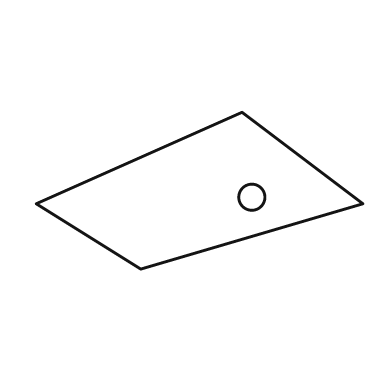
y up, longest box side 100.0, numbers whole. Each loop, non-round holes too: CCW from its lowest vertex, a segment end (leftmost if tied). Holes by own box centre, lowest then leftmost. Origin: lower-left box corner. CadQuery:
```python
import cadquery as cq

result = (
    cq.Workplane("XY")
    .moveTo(32.0, 0.0)
    .lineTo(100.0, 20.0)
    .lineTo(63.0, 48.0)
    .lineTo(0.0, 20.0)
    .close()
    .moveTo(66.0, 22.0)
    .circle(4.0)
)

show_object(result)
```